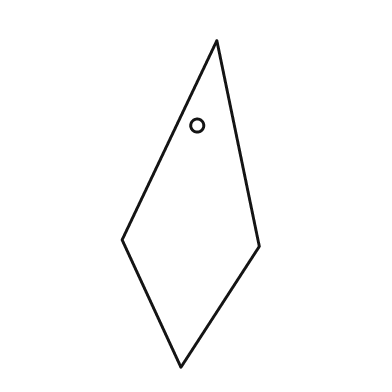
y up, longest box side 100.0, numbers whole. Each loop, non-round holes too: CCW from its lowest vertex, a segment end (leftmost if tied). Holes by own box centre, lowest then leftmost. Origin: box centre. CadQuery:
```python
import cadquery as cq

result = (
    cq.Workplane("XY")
    .moveTo(-3.0, -50.0)
    .lineTo(21.0, -13.0)
    .lineTo(8.0, 50.0)
    .lineTo(-21.0, -11.0)
    .close()
    .moveTo(2.0, 24.0)
    .circle(2.0)
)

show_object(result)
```